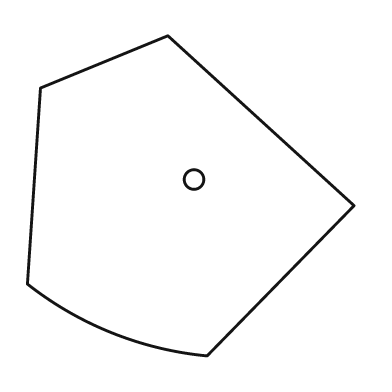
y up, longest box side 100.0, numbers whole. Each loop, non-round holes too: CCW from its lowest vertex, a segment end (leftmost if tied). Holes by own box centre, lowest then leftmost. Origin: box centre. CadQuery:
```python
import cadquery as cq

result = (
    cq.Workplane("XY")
    .moveTo(5.0, -49.0)
    .lineTo(50.0, -3.0)
    .lineTo(-7.0, 49.0)
    .lineTo(-46.0, 33.0)
    .lineTo(-50.0, -27.0)
    .threePointArc((-24.0, -42.0), (5.0, -49.0))
    .close()
    .moveTo(1.0, 5.0)
    .circle(3.0)
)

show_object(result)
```